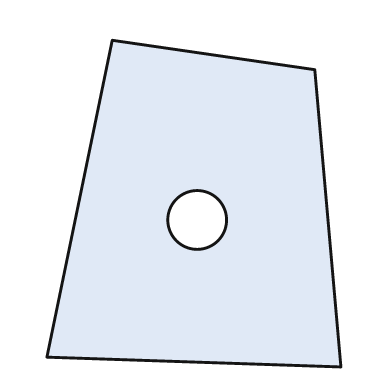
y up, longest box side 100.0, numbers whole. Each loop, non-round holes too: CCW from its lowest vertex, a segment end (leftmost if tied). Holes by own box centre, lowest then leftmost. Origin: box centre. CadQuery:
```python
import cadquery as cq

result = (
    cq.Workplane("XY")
    .moveTo(45.0, -50.0)
    .lineTo(37.0, 41.0)
    .lineTo(-25.0, 50.0)
    .lineTo(-45.0, -47.0)
    .close()
    .moveTo(1.0, -5.0)
    .circle(9.0)
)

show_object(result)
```